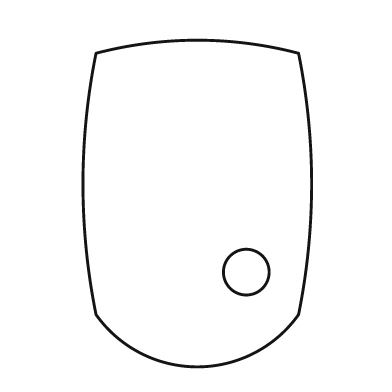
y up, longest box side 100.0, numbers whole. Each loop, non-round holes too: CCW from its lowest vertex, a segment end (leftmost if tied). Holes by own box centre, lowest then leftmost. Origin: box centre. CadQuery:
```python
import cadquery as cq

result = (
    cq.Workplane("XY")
    .moveTo(-31.0, -34.0)
    .threePointArc((0.0, -50.0), (31.0, -34.0))
    .threePointArc((35.0, 6.0), (31.0, 46.0))
    .threePointArc((0.0, 50.0), (-31.0, 46.0))
    .threePointArc((-35.0, 6.0), (-31.0, -34.0))
    .close()
    .moveTo(15.0, -21.0)
    .circle(7.0)
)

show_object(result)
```